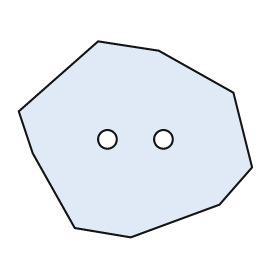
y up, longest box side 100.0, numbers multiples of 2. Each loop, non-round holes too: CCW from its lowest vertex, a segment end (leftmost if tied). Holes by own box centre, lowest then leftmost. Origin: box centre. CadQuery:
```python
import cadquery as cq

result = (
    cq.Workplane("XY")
    .moveTo(-2.0, -42.0)
    .lineTo(36.0, -28.0)
    .lineTo(50.0, -12.0)
    .lineTo(42.0, 20.0)
    .lineTo(10.0, 38.0)
    .lineTo(-16.0, 42.0)
    .lineTo(-50.0, 12.0)
    .lineTo(-44.0, -6.0)
    .lineTo(-26.0, -38.0)
    .close()
    .moveTo(-12.0, 0.0)
    .circle(4.0)
    .moveTo(12.0, 0.0)
    .circle(4.0)
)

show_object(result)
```